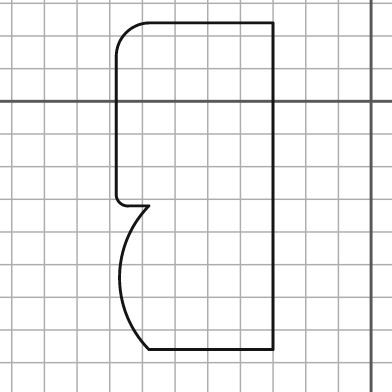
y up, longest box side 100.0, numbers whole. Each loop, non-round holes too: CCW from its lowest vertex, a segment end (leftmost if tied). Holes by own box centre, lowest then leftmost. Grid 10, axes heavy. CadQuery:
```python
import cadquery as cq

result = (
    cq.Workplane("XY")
    .moveTo(-68.0, -76.0)
    .lineTo(-30.0, -76.0)
    .lineTo(-30.0, 24.0)
    .lineTo(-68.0, 24.0)
    .threePointArc((-75.0, 21.0), (-78.0, 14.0))
    .lineTo(-78.0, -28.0)
    .threePointArc((-77.0, -31.0), (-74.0, -32.0))
    .lineTo(-68.0, -32.0)
    .threePointArc((-77.0, -54.0), (-68.0, -76.0))
    .close()
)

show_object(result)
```